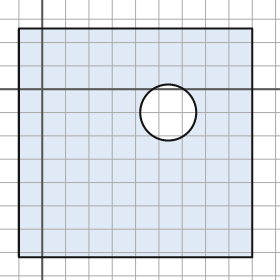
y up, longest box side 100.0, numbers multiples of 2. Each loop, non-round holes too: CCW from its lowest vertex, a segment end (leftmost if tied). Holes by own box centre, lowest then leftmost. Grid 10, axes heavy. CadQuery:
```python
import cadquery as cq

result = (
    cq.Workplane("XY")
    .moveTo(-10.0, -72.0)
    .lineTo(90.0, -72.0)
    .lineTo(90.0, 26.0)
    .lineTo(-10.0, 26.0)
    .close()
    .moveTo(54.0, -10.0)
    .circle(12.0)
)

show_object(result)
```